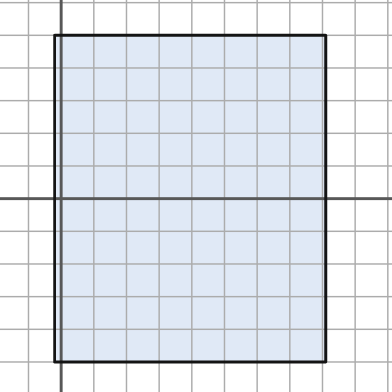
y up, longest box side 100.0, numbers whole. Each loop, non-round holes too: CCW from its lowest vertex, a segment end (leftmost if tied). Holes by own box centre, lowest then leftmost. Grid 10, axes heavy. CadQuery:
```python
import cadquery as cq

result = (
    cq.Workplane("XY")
    .moveTo(-2.0, -50.0)
    .lineTo(81.0, -50.0)
    .lineTo(81.0, 50.0)
    .lineTo(-2.0, 50.0)
    .close()
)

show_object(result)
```